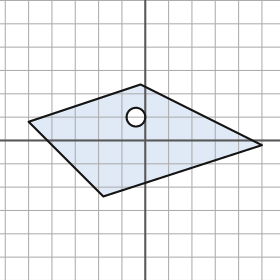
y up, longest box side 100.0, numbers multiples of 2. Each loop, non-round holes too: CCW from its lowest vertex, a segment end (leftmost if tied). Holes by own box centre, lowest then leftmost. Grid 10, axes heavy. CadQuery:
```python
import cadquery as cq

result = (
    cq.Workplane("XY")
    .moveTo(-18.0, -24.0)
    .lineTo(50.0, -2.0)
    .lineTo(-2.0, 24.0)
    .lineTo(-50.0, 8.0)
    .close()
    .moveTo(-4.0, 10.0)
    .circle(4.0)
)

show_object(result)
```